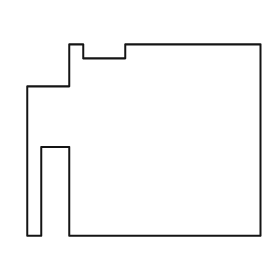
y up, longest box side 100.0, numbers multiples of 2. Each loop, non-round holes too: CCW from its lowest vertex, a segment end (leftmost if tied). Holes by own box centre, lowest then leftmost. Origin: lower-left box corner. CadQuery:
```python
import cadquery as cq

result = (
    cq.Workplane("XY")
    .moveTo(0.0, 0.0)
    .lineTo(6.0, 0.0)
    .lineTo(6.0, 38.0)
    .lineTo(18.0, 38.0)
    .lineTo(18.0, 0.0)
    .lineTo(100.0, 0.0)
    .lineTo(100.0, 82.0)
    .lineTo(42.0, 82.0)
    .lineTo(42.0, 76.0)
    .lineTo(24.0, 76.0)
    .lineTo(24.0, 82.0)
    .lineTo(18.0, 82.0)
    .lineTo(18.0, 64.0)
    .lineTo(0.0, 64.0)
    .close()
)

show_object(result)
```